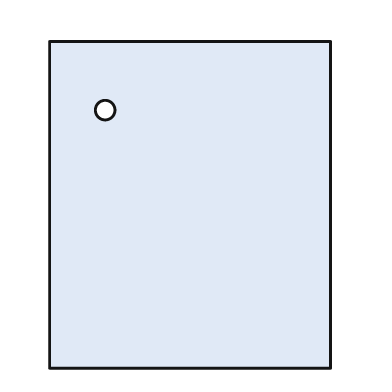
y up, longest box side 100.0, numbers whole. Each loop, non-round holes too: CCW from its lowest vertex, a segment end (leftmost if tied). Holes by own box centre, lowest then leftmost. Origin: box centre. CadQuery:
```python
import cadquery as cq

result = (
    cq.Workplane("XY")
    .moveTo(-43.0, -50.0)
    .lineTo(43.0, -50.0)
    .lineTo(43.0, 50.0)
    .lineTo(-43.0, 50.0)
    .close()
    .moveTo(-26.0, 29.0)
    .circle(3.0)
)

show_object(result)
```